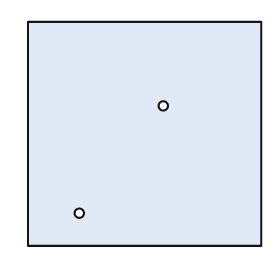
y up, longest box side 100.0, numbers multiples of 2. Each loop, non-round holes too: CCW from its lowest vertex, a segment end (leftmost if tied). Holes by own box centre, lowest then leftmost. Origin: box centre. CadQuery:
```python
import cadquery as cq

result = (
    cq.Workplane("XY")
    .moveTo(-50.0, -48.0)
    .lineTo(50.0, -48.0)
    .lineTo(50.0, 48.0)
    .lineTo(-50.0, 48.0)
    .close()
    .moveTo(-28.0, -34.0)
    .circle(2.0)
    .moveTo(8.0, 12.0)
    .circle(2.0)
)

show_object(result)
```